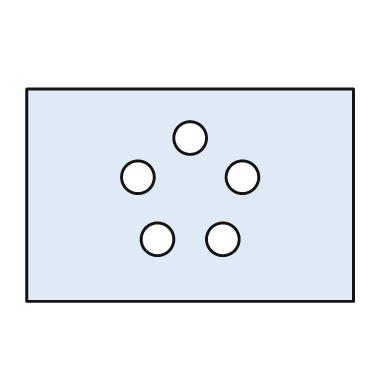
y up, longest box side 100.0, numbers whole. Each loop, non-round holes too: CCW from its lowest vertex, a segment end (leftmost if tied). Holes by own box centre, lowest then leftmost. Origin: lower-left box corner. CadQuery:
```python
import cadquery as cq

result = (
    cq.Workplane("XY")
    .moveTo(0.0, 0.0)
    .lineTo(100.0, 0.0)
    .lineTo(100.0, 65.0)
    .lineTo(0.0, 65.0)
    .close()
    .moveTo(40.0, 19.0)
    .circle(5.0)
    .moveTo(60.0, 19.0)
    .circle(5.0)
    .moveTo(34.0, 38.0)
    .circle(5.0)
    .moveTo(66.0, 38.0)
    .circle(5.0)
    .moveTo(50.0, 50.0)
    .circle(5.0)
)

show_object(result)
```